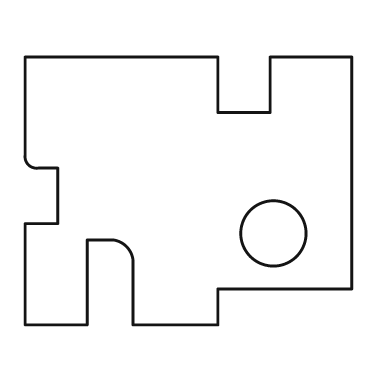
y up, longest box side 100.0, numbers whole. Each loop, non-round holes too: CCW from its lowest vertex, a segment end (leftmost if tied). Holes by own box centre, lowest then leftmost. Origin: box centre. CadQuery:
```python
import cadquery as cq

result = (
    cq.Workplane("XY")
    .moveTo(-50.0, -41.0)
    .lineTo(-31.0, -41.0)
    .lineTo(-31.0, -15.0)
    .lineTo(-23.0, -15.0)
    .threePointArc((-19.0, -17.0), (-17.0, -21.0))
    .lineTo(-17.0, -41.0)
    .lineTo(9.0, -41.0)
    .lineTo(9.0, -30.0)
    .lineTo(50.0, -30.0)
    .lineTo(50.0, 41.0)
    .lineTo(25.0, 41.0)
    .lineTo(25.0, 24.0)
    .lineTo(9.0, 24.0)
    .lineTo(9.0, 41.0)
    .lineTo(-50.0, 41.0)
    .lineTo(-50.0, 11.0)
    .threePointArc((-49.0, 8.0), (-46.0, 7.0))
    .lineTo(-40.0, 7.0)
    .lineTo(-40.0, -10.0)
    .lineTo(-50.0, -10.0)
    .close()
    .moveTo(26.0, -13.0)
    .circle(10.0)
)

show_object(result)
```